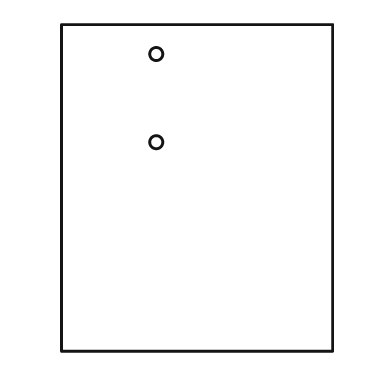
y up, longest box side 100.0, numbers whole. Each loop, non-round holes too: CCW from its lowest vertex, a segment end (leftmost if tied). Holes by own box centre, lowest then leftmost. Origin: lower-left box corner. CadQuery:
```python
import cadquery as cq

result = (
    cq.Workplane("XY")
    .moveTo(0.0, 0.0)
    .lineTo(83.0, 0.0)
    .lineTo(83.0, 100.0)
    .lineTo(0.0, 100.0)
    .close()
    .moveTo(29.0, 64.0)
    .circle(2.0)
    .moveTo(29.0, 91.0)
    .circle(2.0)
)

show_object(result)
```